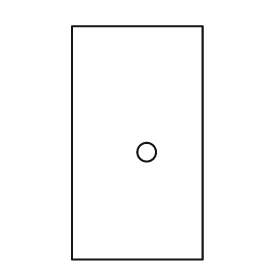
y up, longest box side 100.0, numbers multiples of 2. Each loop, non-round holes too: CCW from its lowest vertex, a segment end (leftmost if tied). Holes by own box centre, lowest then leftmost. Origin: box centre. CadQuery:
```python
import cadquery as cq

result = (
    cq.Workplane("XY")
    .moveTo(-28.0, -50.0)
    .lineTo(28.0, -50.0)
    .lineTo(28.0, 50.0)
    .lineTo(-28.0, 50.0)
    .close()
    .moveTo(4.0, -4.0)
    .circle(4.0)
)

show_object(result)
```